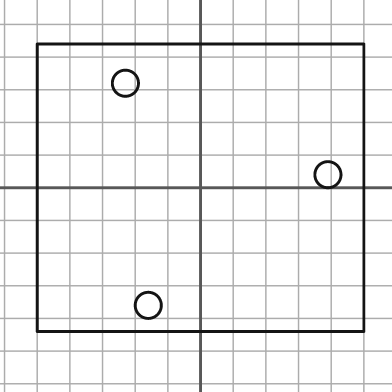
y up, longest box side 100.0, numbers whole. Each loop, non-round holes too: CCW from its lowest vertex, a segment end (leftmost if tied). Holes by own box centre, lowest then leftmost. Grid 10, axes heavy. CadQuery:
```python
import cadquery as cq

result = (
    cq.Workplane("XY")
    .moveTo(-50.0, -44.0)
    .lineTo(50.0, -44.0)
    .lineTo(50.0, 44.0)
    .lineTo(-50.0, 44.0)
    .close()
    .moveTo(-16.0, -36.0)
    .circle(4.0)
    .moveTo(39.0, 4.0)
    .circle(4.0)
    .moveTo(-23.0, 32.0)
    .circle(4.0)
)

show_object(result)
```